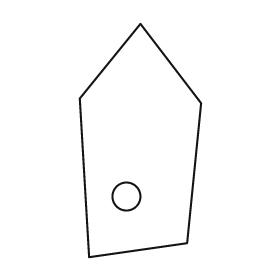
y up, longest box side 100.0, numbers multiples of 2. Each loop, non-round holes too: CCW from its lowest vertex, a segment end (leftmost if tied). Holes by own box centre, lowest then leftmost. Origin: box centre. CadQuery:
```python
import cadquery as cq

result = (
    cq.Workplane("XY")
    .moveTo(-22.0, -50.0)
    .lineTo(20.0, -44.0)
    .lineTo(26.0, 16.0)
    .lineTo(0.0, 50.0)
    .lineTo(-26.0, 18.0)
    .close()
    .moveTo(-6.0, -24.0)
    .circle(6.0)
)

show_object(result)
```